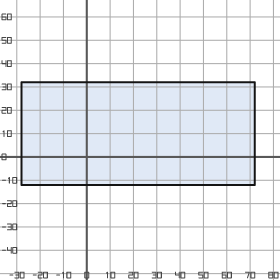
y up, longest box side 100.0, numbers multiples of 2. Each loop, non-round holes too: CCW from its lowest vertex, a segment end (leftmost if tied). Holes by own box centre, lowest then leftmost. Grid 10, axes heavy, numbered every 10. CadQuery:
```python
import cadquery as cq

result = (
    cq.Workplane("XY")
    .moveTo(-28.0, -12.0)
    .lineTo(72.0, -12.0)
    .lineTo(72.0, 32.0)
    .lineTo(-28.0, 32.0)
    .close()
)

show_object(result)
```